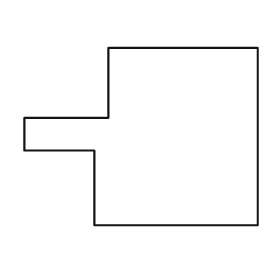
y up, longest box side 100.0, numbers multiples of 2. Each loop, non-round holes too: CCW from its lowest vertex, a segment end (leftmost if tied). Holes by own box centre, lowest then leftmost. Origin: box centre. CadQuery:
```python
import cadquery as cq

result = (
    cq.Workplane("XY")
    .moveTo(-20.0, -38.0)
    .lineTo(50.0, -38.0)
    .lineTo(50.0, 38.0)
    .lineTo(-14.0, 38.0)
    .lineTo(-14.0, 8.0)
    .lineTo(-50.0, 8.0)
    .lineTo(-50.0, -6.0)
    .lineTo(-20.0, -6.0)
    .close()
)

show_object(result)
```